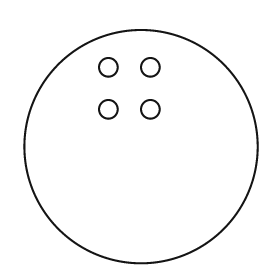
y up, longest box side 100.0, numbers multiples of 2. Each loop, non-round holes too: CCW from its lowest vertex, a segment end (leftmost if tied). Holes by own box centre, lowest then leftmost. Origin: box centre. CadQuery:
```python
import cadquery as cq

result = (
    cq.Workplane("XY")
    .moveTo(0.0, 0.0)
    .circle(50.0)
    .moveTo(-14.0, 16.0)
    .circle(4.0)
    .moveTo(4.0, 16.0)
    .circle(4.0)
    .moveTo(-14.0, 34.0)
    .circle(4.0)
    .moveTo(4.0, 34.0)
    .circle(4.0)
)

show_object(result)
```